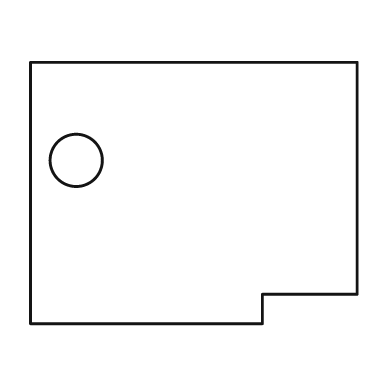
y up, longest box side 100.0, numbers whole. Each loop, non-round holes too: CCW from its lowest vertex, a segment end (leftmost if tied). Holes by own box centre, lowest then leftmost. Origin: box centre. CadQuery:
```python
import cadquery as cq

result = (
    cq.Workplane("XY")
    .moveTo(-50.0, -40.0)
    .lineTo(21.0, -40.0)
    .lineTo(21.0, -31.0)
    .lineTo(50.0, -31.0)
    .lineTo(50.0, 40.0)
    .lineTo(-50.0, 40.0)
    .close()
    .moveTo(-36.0, 10.0)
    .circle(8.0)
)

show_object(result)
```